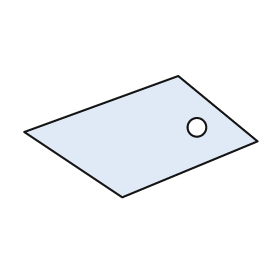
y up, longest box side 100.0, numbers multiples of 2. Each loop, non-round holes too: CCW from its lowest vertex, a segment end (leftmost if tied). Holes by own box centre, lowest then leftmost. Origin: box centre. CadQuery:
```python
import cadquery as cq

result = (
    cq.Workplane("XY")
    .moveTo(-8.0, -26.0)
    .lineTo(50.0, -2.0)
    .lineTo(16.0, 26.0)
    .lineTo(-50.0, 2.0)
    .close()
    .moveTo(24.0, 4.0)
    .circle(4.0)
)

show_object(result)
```